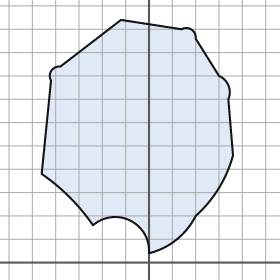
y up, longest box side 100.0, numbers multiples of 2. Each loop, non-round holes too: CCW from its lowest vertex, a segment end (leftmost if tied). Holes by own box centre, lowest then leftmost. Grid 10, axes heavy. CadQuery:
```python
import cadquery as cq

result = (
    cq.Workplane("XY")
    .moveTo(0.0, 4.0)
    .threePointArc((12.0, 10.0), (20.0, 20.0))
    .threePointArc((30.0, 32.0), (36.0, 46.0))
    .lineTo(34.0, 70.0)
    .threePointArc((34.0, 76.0), (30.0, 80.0))
    .lineTo(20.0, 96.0)
    .threePointArc((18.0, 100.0), (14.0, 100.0))
    .lineTo(-12.0, 104.0)
    .lineTo(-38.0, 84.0)
    .threePointArc((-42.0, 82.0), (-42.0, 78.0))
    .lineTo(-46.0, 38.0)
    .threePointArc((-34.0, 28.0), (-24.0, 16.0))
    .threePointArc((-8.0, 18.0), (0.0, 4.0))
    .close()
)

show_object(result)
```